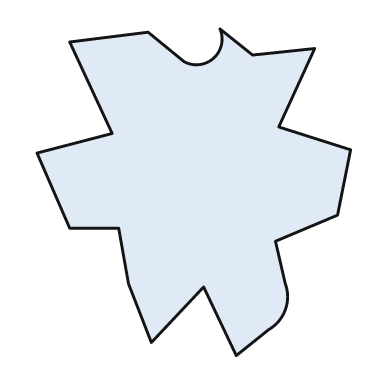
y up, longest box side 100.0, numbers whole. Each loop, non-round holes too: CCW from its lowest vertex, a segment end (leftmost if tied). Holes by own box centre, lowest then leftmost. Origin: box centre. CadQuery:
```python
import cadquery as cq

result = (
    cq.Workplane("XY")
    .moveTo(13.0, -50.0)
    .lineTo(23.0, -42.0)
    .threePointArc((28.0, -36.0), (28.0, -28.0))
    .lineTo(25.0, -15.0)
    .lineTo(44.0, -7.0)
    .lineTo(48.0, 13.0)
    .lineTo(26.0, 20.0)
    .lineTo(37.0, 44.0)
    .lineTo(18.0, 42.0)
    .lineTo(8.0, 50.0)
    .threePointArc((6.0, 41.0), (-3.0, 40.0))
    .lineTo(-14.0, 49.0)
    .lineTo(-38.0, 46.0)
    .lineTo(-25.0, 18.0)
    .lineTo(-48.0, 12.0)
    .lineTo(-38.0, -11.0)
    .lineTo(-23.0, -11.0)
    .lineTo(-20.0, -28.0)
    .lineTo(-13.0, -46.0)
    .lineTo(3.0, -29.0)
    .close()
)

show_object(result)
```